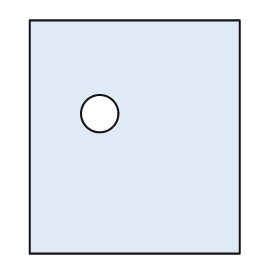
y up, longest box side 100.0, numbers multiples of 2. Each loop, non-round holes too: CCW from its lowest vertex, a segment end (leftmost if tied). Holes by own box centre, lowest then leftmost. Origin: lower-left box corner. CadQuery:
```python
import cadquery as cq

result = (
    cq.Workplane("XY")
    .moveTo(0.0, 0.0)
    .lineTo(90.0, 0.0)
    .lineTo(90.0, 100.0)
    .lineTo(0.0, 100.0)
    .close()
    .moveTo(30.0, 60.0)
    .circle(8.0)
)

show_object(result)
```